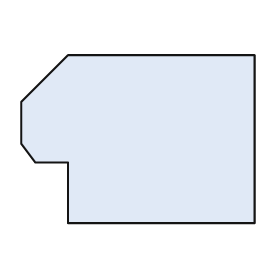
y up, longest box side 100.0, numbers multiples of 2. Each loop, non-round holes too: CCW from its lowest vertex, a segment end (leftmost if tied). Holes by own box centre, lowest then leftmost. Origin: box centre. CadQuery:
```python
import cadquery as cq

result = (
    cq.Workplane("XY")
    .moveTo(-30.0, -36.0)
    .lineTo(50.0, -36.0)
    .lineTo(50.0, 36.0)
    .lineTo(-30.0, 36.0)
    .lineTo(-50.0, 16.0)
    .lineTo(-50.0, -2.0)
    .lineTo(-44.0, -10.0)
    .lineTo(-30.0, -10.0)
    .close()
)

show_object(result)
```